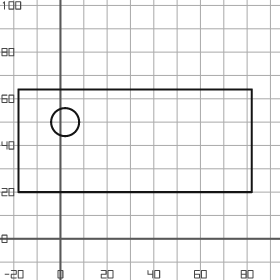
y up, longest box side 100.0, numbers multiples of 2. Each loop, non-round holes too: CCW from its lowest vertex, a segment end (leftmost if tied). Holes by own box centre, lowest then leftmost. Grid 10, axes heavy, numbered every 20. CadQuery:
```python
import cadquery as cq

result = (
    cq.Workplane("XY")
    .moveTo(-18.0, 20.0)
    .lineTo(82.0, 20.0)
    .lineTo(82.0, 64.0)
    .lineTo(-18.0, 64.0)
    .close()
    .moveTo(2.0, 50.0)
    .circle(6.0)
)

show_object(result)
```